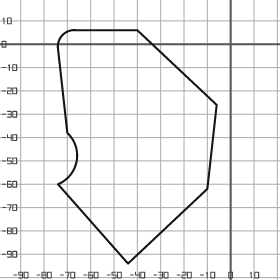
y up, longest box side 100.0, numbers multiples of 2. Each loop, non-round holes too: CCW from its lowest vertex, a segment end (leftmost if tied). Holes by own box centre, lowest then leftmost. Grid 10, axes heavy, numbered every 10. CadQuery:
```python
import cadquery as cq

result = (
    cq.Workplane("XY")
    .moveTo(-44.0, -94.0)
    .lineTo(-10.0, -62.0)
    .lineTo(-6.0, -26.0)
    .lineTo(-40.0, 6.0)
    .lineTo(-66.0, 6.0)
    .threePointArc((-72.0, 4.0), (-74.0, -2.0))
    .lineTo(-70.0, -38.0)
    .threePointArc((-66.0, -50.0), (-74.0, -60.0))
    .close()
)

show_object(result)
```